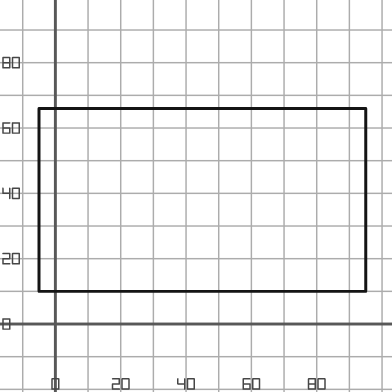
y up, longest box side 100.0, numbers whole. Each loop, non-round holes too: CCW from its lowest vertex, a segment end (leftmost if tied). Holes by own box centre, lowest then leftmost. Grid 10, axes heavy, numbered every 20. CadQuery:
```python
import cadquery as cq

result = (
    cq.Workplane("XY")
    .moveTo(-5.0, 10.0)
    .lineTo(95.0, 10.0)
    .lineTo(95.0, 66.0)
    .lineTo(-5.0, 66.0)
    .close()
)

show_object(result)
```